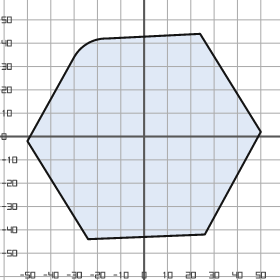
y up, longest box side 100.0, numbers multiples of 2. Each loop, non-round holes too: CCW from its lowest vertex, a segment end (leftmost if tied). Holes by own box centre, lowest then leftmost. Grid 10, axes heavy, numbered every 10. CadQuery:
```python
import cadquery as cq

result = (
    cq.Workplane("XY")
    .moveTo(-24.0, -44.0)
    .lineTo(26.0, -42.0)
    .lineTo(50.0, 2.0)
    .lineTo(24.0, 44.0)
    .lineTo(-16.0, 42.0)
    .threePointArc((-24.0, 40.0), (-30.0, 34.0))
    .lineTo(-50.0, -2.0)
    .close()
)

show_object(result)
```